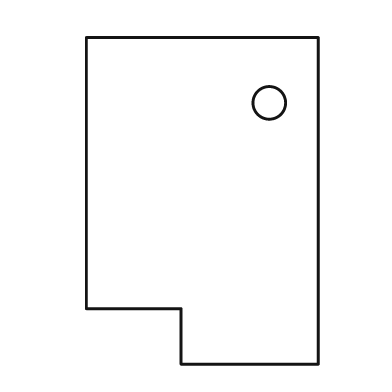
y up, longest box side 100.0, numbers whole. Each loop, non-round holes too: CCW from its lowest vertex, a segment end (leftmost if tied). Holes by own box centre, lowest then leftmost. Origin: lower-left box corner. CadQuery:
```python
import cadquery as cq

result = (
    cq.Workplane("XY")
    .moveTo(29.0, 0.0)
    .lineTo(71.0, 0.0)
    .lineTo(71.0, 100.0)
    .lineTo(0.0, 100.0)
    .lineTo(0.0, 17.0)
    .lineTo(29.0, 17.0)
    .close()
    .moveTo(56.0, 80.0)
    .circle(5.0)
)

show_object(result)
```